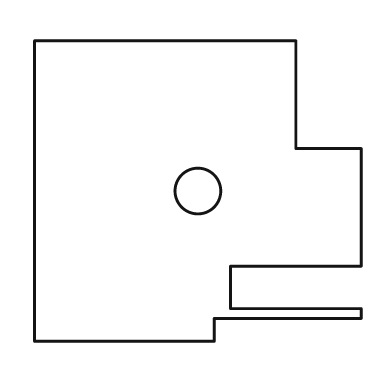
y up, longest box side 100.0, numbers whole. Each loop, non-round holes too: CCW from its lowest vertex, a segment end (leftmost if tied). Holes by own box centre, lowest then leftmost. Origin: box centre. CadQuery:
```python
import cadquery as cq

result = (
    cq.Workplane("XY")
    .moveTo(-50.0, -46.0)
    .lineTo(5.0, -46.0)
    .lineTo(5.0, -39.0)
    .lineTo(50.0, -39.0)
    .lineTo(50.0, -36.0)
    .lineTo(10.0, -36.0)
    .lineTo(10.0, -23.0)
    .lineTo(50.0, -23.0)
    .lineTo(50.0, 13.0)
    .lineTo(30.0, 13.0)
    .lineTo(30.0, 46.0)
    .lineTo(-50.0, 46.0)
    .close()
    .moveTo(0.0, 0.0)
    .circle(7.0)
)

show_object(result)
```